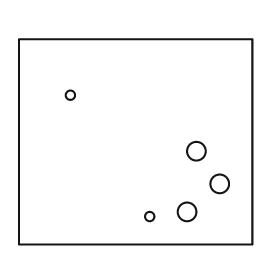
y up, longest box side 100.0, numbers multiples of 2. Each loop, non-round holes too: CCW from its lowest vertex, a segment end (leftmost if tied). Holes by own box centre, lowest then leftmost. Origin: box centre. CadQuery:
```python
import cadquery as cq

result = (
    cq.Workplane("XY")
    .moveTo(-50.0, -44.0)
    .lineTo(50.0, -44.0)
    .lineTo(50.0, 44.0)
    .lineTo(-50.0, 44.0)
    .close()
    .moveTo(6.0, -32.0)
    .circle(2.0)
    .moveTo(22.0, -30.0)
    .circle(4.0)
    .moveTo(36.0, -18.0)
    .circle(4.0)
    .moveTo(26.0, -4.0)
    .circle(4.0)
    .moveTo(-28.0, 20.0)
    .circle(2.0)
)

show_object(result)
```